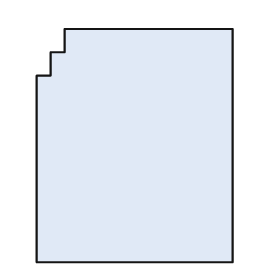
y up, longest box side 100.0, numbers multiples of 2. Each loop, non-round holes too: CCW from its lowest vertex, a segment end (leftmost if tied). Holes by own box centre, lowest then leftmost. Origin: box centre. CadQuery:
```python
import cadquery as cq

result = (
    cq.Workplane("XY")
    .moveTo(-42.0, -50.0)
    .lineTo(42.0, -50.0)
    .lineTo(42.0, 50.0)
    .lineTo(-30.0, 50.0)
    .lineTo(-30.0, 40.0)
    .lineTo(-36.0, 40.0)
    .lineTo(-36.0, 30.0)
    .lineTo(-42.0, 30.0)
    .close()
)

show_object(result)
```